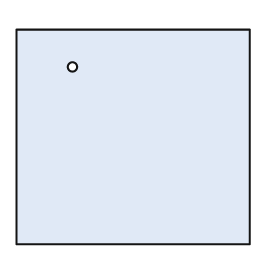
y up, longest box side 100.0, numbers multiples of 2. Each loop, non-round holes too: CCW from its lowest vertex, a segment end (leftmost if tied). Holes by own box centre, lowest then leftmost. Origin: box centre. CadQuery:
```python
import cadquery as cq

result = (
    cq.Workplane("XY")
    .moveTo(-50.0, -46.0)
    .lineTo(50.0, -46.0)
    .lineTo(50.0, 46.0)
    .lineTo(-50.0, 46.0)
    .close()
    .moveTo(-26.0, 30.0)
    .circle(2.0)
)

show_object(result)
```